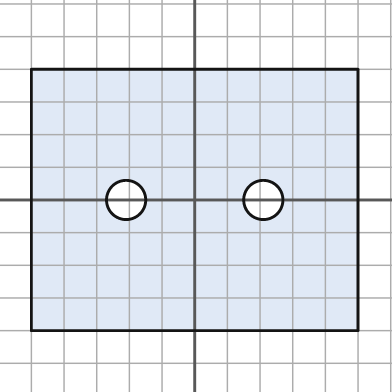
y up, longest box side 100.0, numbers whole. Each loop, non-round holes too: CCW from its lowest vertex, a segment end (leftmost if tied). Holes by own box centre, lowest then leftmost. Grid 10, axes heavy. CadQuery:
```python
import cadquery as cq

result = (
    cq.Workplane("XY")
    .moveTo(-50.0, -40.0)
    .lineTo(50.0, -40.0)
    .lineTo(50.0, 40.0)
    .lineTo(-50.0, 40.0)
    .close()
    .moveTo(-21.0, 0.0)
    .circle(6.0)
    .moveTo(21.0, 0.0)
    .circle(6.0)
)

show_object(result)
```